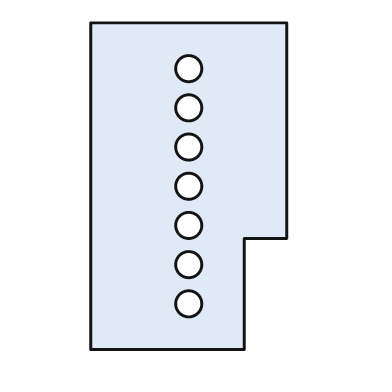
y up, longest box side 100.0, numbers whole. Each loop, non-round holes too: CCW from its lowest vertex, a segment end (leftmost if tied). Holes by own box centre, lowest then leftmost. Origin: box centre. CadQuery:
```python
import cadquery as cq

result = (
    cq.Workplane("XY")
    .moveTo(-30.0, -50.0)
    .lineTo(17.0, -50.0)
    .lineTo(17.0, -16.0)
    .lineTo(30.0, -16.0)
    .lineTo(30.0, 50.0)
    .lineTo(-30.0, 50.0)
    .close()
    .moveTo(0.0, -36.0)
    .circle(4.0)
    .moveTo(0.0, -24.0)
    .circle(4.0)
    .moveTo(0.0, -12.0)
    .circle(4.0)
    .moveTo(0.0, 0.0)
    .circle(4.0)
    .moveTo(0.0, 12.0)
    .circle(4.0)
    .moveTo(0.0, 24.0)
    .circle(4.0)
    .moveTo(0.0, 36.0)
    .circle(4.0)
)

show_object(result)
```